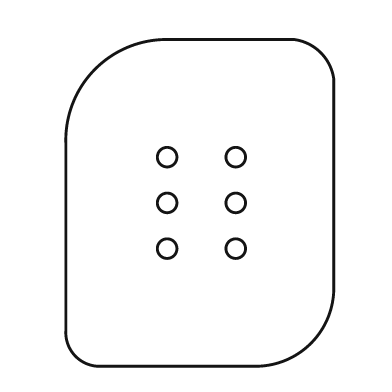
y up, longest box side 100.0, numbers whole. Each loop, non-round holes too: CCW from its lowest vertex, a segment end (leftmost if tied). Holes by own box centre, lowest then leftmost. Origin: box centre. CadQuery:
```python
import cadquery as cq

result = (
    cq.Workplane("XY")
    .moveTo(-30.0, -50.0)
    .lineTo(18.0, -50.0)
    .threePointArc((34.0, -43.0), (41.0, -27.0))
    .lineTo(41.0, 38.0)
    .threePointArc((37.0, 46.0), (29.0, 50.0))
    .lineTo(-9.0, 50.0)
    .threePointArc((-32.0, 41.0), (-41.0, 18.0))
    .lineTo(-41.0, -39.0)
    .threePointArc((-38.0, -47.0), (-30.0, -50.0))
    .close()
    .moveTo(-10.0, -14.0)
    .circle(3.0)
    .moveTo(11.0, -14.0)
    .circle(3.0)
    .moveTo(-10.0, 0.0)
    .circle(3.0)
    .moveTo(11.0, 0.0)
    .circle(3.0)
    .moveTo(-10.0, 14.0)
    .circle(3.0)
    .moveTo(11.0, 14.0)
    .circle(3.0)
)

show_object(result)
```